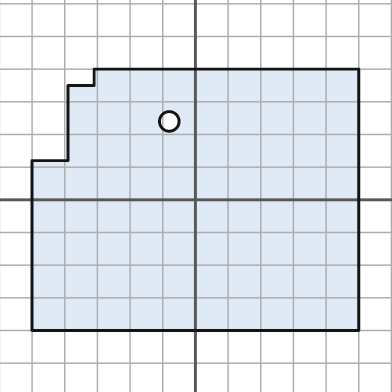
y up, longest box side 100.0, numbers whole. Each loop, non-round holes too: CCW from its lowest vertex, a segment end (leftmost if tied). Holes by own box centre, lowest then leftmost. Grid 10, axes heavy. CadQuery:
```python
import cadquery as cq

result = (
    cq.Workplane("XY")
    .moveTo(-50.0, -40.0)
    .lineTo(50.0, -40.0)
    .lineTo(50.0, 40.0)
    .lineTo(-31.0, 40.0)
    .lineTo(-31.0, 35.0)
    .lineTo(-39.0, 35.0)
    .lineTo(-39.0, 12.0)
    .lineTo(-50.0, 12.0)
    .close()
    .moveTo(-8.0, 24.0)
    .circle(3.0)
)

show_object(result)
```